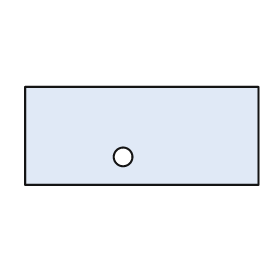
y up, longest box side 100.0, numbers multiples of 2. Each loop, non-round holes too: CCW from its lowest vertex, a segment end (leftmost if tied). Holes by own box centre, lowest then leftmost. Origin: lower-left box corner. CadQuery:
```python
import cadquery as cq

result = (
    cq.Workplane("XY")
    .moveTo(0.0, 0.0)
    .lineTo(100.0, 0.0)
    .lineTo(100.0, 42.0)
    .lineTo(0.0, 42.0)
    .close()
    .moveTo(42.0, 12.0)
    .circle(4.0)
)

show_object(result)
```